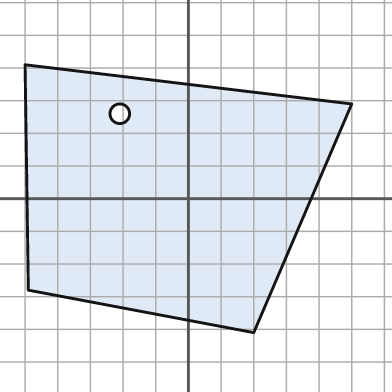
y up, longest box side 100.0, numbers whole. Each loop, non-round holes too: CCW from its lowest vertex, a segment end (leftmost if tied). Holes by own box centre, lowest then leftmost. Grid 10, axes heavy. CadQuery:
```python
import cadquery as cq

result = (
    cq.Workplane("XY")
    .moveTo(20.0, -41.0)
    .lineTo(50.0, 29.0)
    .lineTo(-50.0, 41.0)
    .lineTo(-49.0, -28.0)
    .close()
    .moveTo(-21.0, 26.0)
    .circle(3.0)
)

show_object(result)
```